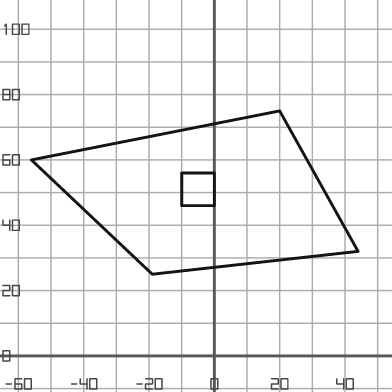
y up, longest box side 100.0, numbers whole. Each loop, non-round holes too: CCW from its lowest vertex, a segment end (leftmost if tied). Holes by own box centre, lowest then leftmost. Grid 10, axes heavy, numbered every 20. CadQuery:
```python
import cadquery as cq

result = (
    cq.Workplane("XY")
    .moveTo(-19.0, 25.0)
    .lineTo(44.0, 32.0)
    .lineTo(20.0, 75.0)
    .lineTo(-56.0, 60.0)
    .close()
    .moveTo(-10.0, 46.0)
    .lineTo(0.0, 46.0)
    .lineTo(0.0, 56.0)
    .lineTo(-10.0, 56.0)
    .close()
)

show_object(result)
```